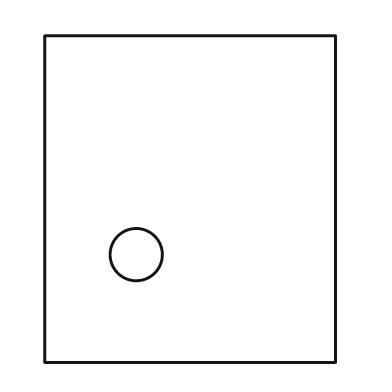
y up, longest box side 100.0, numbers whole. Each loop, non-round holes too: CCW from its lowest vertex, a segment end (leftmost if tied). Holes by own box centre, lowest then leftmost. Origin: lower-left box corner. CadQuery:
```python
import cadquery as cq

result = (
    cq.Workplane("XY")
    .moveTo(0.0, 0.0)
    .lineTo(89.0, 0.0)
    .lineTo(89.0, 100.0)
    .lineTo(0.0, 100.0)
    .close()
    .moveTo(28.0, 33.0)
    .circle(8.0)
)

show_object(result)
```